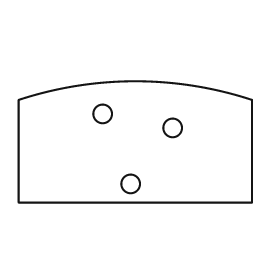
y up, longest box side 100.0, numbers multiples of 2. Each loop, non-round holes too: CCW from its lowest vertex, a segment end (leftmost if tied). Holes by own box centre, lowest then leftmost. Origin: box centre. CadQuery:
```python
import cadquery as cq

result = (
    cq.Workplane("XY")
    .moveTo(-50.0, -26.0)
    .lineTo(50.0, -26.0)
    .lineTo(50.0, 18.0)
    .threePointArc((0.0, 26.0), (-50.0, 18.0))
    .close()
    .moveTo(-2.0, -18.0)
    .circle(4.0)
    .moveTo(16.0, 6.0)
    .circle(4.0)
    .moveTo(-14.0, 12.0)
    .circle(4.0)
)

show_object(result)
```